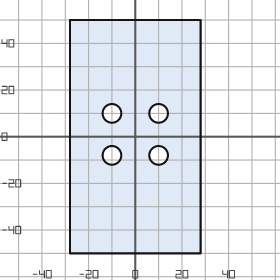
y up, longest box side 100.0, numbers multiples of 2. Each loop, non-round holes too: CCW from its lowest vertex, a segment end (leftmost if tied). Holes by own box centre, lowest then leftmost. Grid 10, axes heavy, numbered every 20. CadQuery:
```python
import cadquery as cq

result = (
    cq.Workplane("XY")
    .moveTo(-28.0, -50.0)
    .lineTo(28.0, -50.0)
    .lineTo(28.0, 50.0)
    .lineTo(-28.0, 50.0)
    .close()
    .moveTo(-10.0, -8.0)
    .circle(4.0)
    .moveTo(10.0, -8.0)
    .circle(4.0)
    .moveTo(-10.0, 10.0)
    .circle(4.0)
    .moveTo(10.0, 10.0)
    .circle(4.0)
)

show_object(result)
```